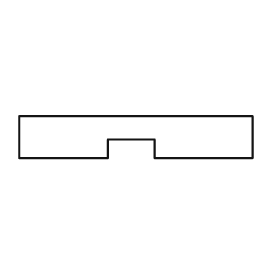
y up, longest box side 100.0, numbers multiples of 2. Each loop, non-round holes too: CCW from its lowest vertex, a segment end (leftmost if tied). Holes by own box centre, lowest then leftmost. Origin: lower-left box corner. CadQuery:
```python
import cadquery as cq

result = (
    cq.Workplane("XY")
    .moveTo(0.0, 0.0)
    .lineTo(38.0, 0.0)
    .lineTo(38.0, 8.0)
    .lineTo(58.0, 8.0)
    .lineTo(58.0, 0.0)
    .lineTo(100.0, 0.0)
    .lineTo(100.0, 18.0)
    .lineTo(0.0, 18.0)
    .close()
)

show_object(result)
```